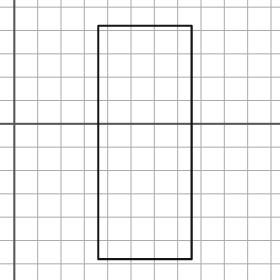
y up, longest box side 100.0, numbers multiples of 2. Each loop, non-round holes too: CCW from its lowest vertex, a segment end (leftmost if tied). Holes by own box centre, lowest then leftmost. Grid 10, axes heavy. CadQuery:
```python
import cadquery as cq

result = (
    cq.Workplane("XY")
    .moveTo(36.0, -58.0)
    .lineTo(76.0, -58.0)
    .lineTo(76.0, 42.0)
    .lineTo(36.0, 42.0)
    .close()
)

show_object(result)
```